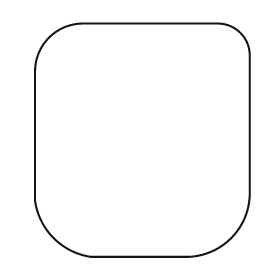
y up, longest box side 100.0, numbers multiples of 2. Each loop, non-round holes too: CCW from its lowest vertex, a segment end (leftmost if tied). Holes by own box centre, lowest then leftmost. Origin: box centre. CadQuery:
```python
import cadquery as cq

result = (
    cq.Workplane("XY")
    .moveTo(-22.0, -50.0)
    .lineTo(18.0, -50.0)
    .threePointArc((38.0, -42.0), (46.0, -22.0))
    .lineTo(46.0, 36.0)
    .threePointArc((42.0, 46.0), (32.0, 50.0))
    .lineTo(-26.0, 50.0)
    .threePointArc((-40.0, 44.0), (-46.0, 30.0))
    .lineTo(-46.0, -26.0)
    .threePointArc((-38.0, -42.0), (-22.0, -50.0))
    .close()
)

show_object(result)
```